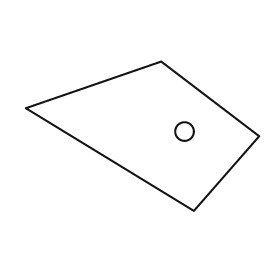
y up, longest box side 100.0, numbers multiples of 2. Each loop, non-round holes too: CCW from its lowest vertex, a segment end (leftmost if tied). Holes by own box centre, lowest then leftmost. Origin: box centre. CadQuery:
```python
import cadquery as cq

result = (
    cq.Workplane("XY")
    .moveTo(22.0, -32.0)
    .lineTo(50.0, 0.0)
    .lineTo(8.0, 32.0)
    .lineTo(-50.0, 12.0)
    .close()
    .moveTo(18.0, 2.0)
    .circle(4.0)
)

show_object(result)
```